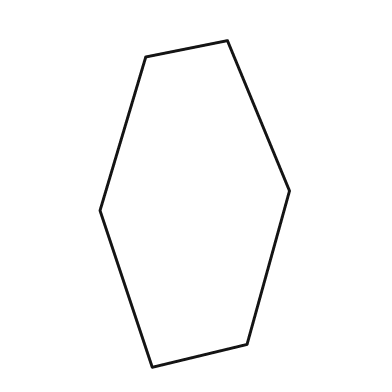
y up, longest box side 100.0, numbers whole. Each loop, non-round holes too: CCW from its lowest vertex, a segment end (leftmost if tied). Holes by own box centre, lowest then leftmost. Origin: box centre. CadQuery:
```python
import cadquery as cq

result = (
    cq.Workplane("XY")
    .moveTo(-13.0, -50.0)
    .lineTo(16.0, -43.0)
    .lineTo(29.0, 4.0)
    .lineTo(10.0, 50.0)
    .lineTo(-15.0, 45.0)
    .lineTo(-29.0, -2.0)
    .close()
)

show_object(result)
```